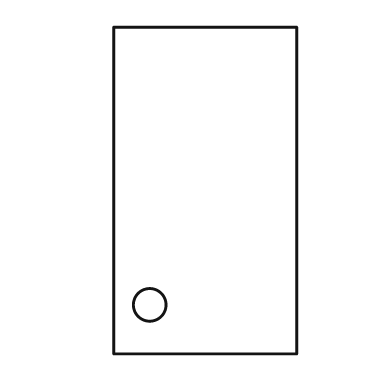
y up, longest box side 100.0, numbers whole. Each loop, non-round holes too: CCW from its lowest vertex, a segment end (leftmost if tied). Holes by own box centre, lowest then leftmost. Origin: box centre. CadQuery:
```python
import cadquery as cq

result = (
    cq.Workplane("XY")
    .moveTo(-28.0, -50.0)
    .lineTo(28.0, -50.0)
    .lineTo(28.0, 50.0)
    .lineTo(-28.0, 50.0)
    .close()
    .moveTo(-17.0, -35.0)
    .circle(5.0)
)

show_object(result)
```